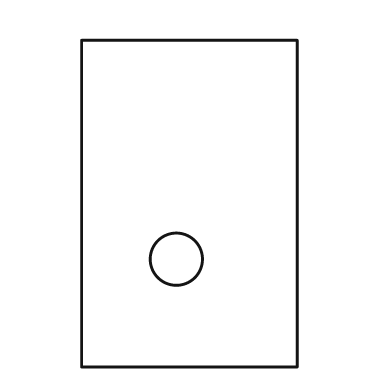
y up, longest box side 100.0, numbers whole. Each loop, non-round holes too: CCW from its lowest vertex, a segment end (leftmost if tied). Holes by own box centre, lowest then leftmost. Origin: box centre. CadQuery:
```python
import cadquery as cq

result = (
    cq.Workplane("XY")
    .moveTo(-33.0, -50.0)
    .lineTo(33.0, -50.0)
    .lineTo(33.0, 50.0)
    .lineTo(-33.0, 50.0)
    .close()
    .moveTo(-4.0, -17.0)
    .circle(8.0)
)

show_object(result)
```